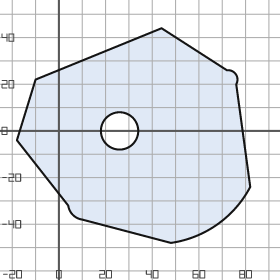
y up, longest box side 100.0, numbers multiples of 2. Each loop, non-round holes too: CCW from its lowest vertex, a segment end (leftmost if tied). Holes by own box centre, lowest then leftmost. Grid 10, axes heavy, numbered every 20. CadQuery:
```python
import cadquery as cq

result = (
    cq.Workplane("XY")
    .moveTo(48.0, -48.0)
    .threePointArc((68.0, -40.0), (82.0, -24.0))
    .lineTo(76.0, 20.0)
    .threePointArc((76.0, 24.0), (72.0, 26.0))
    .lineTo(44.0, 44.0)
    .lineTo(-10.0, 22.0)
    .lineTo(-18.0, -4.0)
    .lineTo(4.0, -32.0)
    .threePointArc((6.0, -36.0), (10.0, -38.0))
    .close()
    .moveTo(26.0, 0.0)
    .circle(8.0)
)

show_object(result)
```